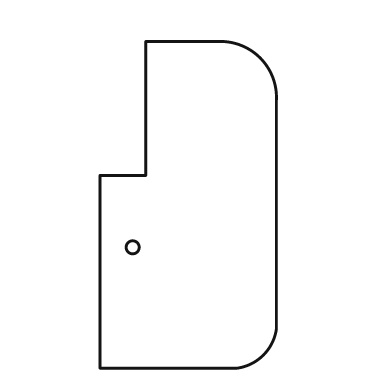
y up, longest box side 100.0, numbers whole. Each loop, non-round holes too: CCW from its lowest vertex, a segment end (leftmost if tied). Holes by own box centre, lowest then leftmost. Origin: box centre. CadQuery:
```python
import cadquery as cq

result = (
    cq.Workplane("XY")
    .moveTo(-27.0, -50.0)
    .lineTo(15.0, -50.0)
    .threePointArc((23.0, -46.0), (27.0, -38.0))
    .lineTo(27.0, 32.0)
    .threePointArc((22.0, 45.0), (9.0, 50.0))
    .lineTo(-13.0, 50.0)
    .lineTo(-13.0, 9.0)
    .lineTo(-27.0, 9.0)
    .close()
    .moveTo(-17.0, -13.0)
    .circle(2.0)
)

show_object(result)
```